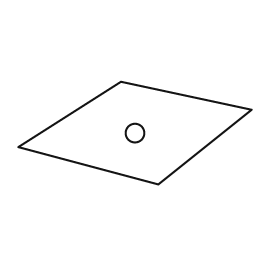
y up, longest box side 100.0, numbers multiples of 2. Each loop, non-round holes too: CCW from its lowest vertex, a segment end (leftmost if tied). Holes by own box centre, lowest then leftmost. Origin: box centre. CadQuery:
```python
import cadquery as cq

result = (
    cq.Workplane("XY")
    .moveTo(10.0, -22.0)
    .lineTo(50.0, 10.0)
    .lineTo(-6.0, 22.0)
    .lineTo(-50.0, -6.0)
    .close()
    .moveTo(0.0, 0.0)
    .circle(4.0)
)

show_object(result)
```